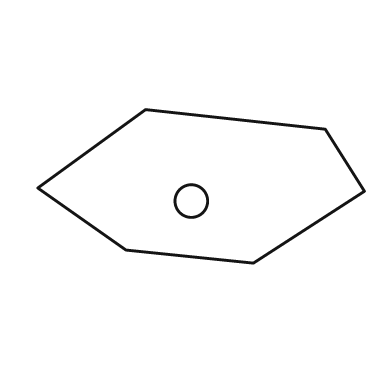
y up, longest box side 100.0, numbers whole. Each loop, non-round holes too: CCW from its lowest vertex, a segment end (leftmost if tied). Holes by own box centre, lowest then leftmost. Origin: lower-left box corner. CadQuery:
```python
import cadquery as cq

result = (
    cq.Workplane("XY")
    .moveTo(66.0, 0.0)
    .lineTo(100.0, 22.0)
    .lineTo(88.0, 41.0)
    .lineTo(33.0, 47.0)
    .lineTo(0.0, 23.0)
    .lineTo(27.0, 4.0)
    .close()
    .moveTo(47.0, 19.0)
    .circle(5.0)
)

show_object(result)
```